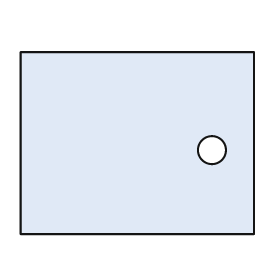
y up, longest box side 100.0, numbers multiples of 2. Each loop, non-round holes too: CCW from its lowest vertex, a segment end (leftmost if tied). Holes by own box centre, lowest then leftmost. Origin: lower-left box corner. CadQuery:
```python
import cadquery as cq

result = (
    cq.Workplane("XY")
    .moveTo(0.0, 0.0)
    .lineTo(100.0, 0.0)
    .lineTo(100.0, 78.0)
    .lineTo(0.0, 78.0)
    .close()
    .moveTo(82.0, 36.0)
    .circle(6.0)
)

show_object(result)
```